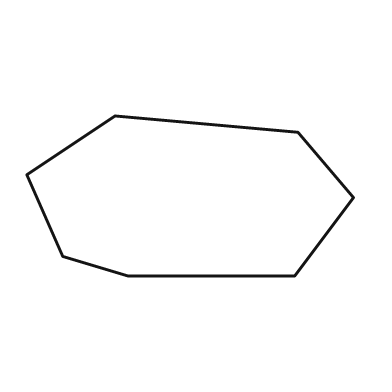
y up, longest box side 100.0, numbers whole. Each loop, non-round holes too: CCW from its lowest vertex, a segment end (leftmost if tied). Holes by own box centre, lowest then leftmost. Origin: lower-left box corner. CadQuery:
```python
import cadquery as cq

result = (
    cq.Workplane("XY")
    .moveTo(31.0, 0.0)
    .lineTo(82.0, 0.0)
    .lineTo(100.0, 24.0)
    .lineTo(83.0, 44.0)
    .lineTo(27.0, 49.0)
    .lineTo(0.0, 31.0)
    .lineTo(11.0, 6.0)
    .close()
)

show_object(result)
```